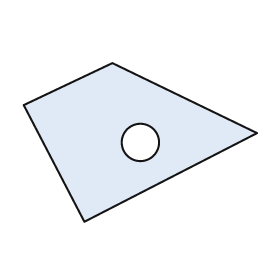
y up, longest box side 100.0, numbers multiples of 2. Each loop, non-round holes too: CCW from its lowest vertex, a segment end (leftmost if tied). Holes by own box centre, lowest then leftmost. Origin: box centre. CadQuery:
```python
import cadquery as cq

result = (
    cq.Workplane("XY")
    .moveTo(-24.0, -34.0)
    .lineTo(50.0, 4.0)
    .lineTo(-12.0, 34.0)
    .lineTo(-50.0, 16.0)
    .close()
    .moveTo(0.0, 0.0)
    .circle(8.0)
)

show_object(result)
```